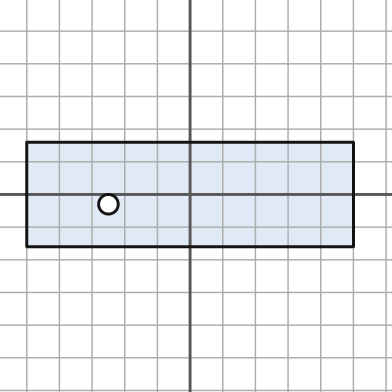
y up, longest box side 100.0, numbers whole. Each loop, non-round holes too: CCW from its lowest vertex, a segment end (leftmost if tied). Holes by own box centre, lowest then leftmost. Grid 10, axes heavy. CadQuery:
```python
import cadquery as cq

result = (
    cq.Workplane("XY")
    .moveTo(-50.0, -16.0)
    .lineTo(50.0, -16.0)
    .lineTo(50.0, 16.0)
    .lineTo(-50.0, 16.0)
    .close()
    .moveTo(-25.0, -3.0)
    .circle(3.0)
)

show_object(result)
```